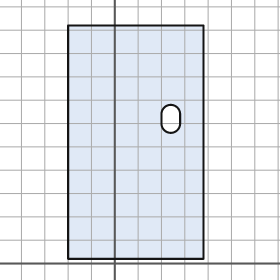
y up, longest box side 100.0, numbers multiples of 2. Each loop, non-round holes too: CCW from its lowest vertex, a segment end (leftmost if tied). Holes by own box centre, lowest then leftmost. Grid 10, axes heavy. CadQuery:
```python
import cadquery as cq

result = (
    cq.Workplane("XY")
    .moveTo(-20.0, 2.0)
    .lineTo(38.0, 2.0)
    .lineTo(38.0, 102.0)
    .lineTo(-20.0, 102.0)
    .close()
    .moveTo(20.0, 60.0)
    .threePointArc((24.0, 56.0), (28.0, 60.0))
    .lineTo(28.0, 64.0)
    .threePointArc((24.0, 68.0), (20.0, 64.0))
    .close()
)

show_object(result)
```